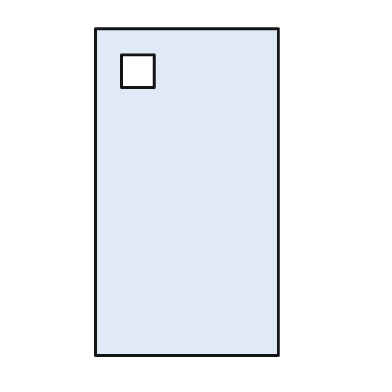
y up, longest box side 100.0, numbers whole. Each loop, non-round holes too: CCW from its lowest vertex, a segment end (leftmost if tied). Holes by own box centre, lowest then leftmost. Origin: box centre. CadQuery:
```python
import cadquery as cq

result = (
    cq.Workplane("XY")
    .moveTo(-28.0, -50.0)
    .lineTo(28.0, -50.0)
    .lineTo(28.0, 50.0)
    .lineTo(-28.0, 50.0)
    .close()
    .moveTo(-20.0, 32.0)
    .lineTo(-10.0, 32.0)
    .lineTo(-10.0, 42.0)
    .lineTo(-20.0, 42.0)
    .close()
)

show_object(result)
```